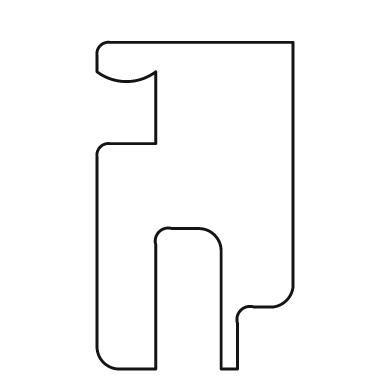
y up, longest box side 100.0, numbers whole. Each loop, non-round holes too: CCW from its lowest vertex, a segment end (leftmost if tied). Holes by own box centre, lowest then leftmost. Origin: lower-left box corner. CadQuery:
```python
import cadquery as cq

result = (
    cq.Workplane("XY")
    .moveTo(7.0, 0.0)
    .lineTo(18.0, 0.0)
    .lineTo(18.0, 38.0)
    .threePointArc((19.0, 42.0), (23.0, 43.0))
    .lineTo(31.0, 43.0)
    .threePointArc((36.0, 41.0), (38.0, 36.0))
    .lineTo(38.0, 0.0)
    .lineTo(43.0, 0.0)
    .lineTo(43.0, 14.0)
    .threePointArc((44.0, 18.0), (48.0, 19.0))
    .lineTo(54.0, 19.0)
    .threePointArc((58.0, 21.0), (60.0, 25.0))
    .lineTo(60.0, 100.0)
    .lineTo(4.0, 100.0)
    .threePointArc((1.0, 99.0), (0.0, 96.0))
    .lineTo(0.0, 91.0)
    .threePointArc((9.0, 88.0), (18.0, 91.0))
    .lineTo(18.0, 69.0)
    .lineTo(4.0, 69.0)
    .threePointArc((1.0, 68.0), (0.0, 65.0))
    .lineTo(0.0, 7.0)
    .threePointArc((2.0, 2.0), (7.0, 0.0))
    .close()
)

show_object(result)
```